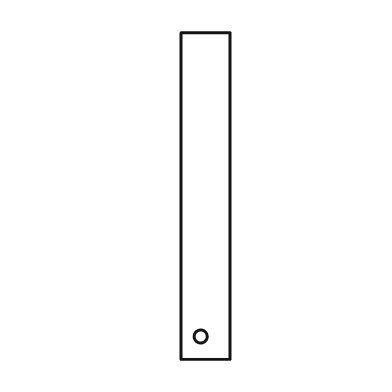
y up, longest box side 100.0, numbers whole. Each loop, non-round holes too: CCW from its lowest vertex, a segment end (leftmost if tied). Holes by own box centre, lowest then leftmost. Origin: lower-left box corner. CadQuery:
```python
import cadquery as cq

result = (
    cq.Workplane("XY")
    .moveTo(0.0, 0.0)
    .lineTo(15.0, 0.0)
    .lineTo(15.0, 100.0)
    .lineTo(0.0, 100.0)
    .close()
    .moveTo(6.0, 7.0)
    .circle(2.0)
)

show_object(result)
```